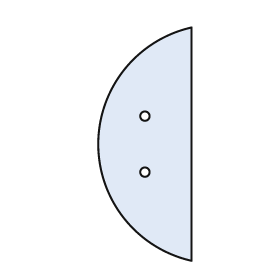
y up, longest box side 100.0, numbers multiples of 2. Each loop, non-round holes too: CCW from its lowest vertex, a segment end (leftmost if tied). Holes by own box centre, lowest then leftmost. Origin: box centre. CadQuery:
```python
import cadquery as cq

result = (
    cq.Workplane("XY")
    .moveTo(20.0, -50.0)
    .lineTo(20.0, 50.0)
    .threePointArc((-20.0, 0.0), (20.0, -50.0))
    .close()
    .moveTo(0.0, -12.0)
    .circle(2.0)
    .moveTo(0.0, 12.0)
    .circle(2.0)
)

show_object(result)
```